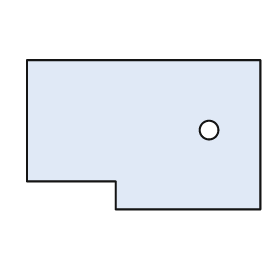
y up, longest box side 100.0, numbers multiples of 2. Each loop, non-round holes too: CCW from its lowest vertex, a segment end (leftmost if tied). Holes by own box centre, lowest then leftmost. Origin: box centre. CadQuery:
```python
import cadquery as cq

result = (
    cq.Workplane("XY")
    .moveTo(-12.0, -32.0)
    .lineTo(50.0, -32.0)
    .lineTo(50.0, 32.0)
    .lineTo(-50.0, 32.0)
    .lineTo(-50.0, -20.0)
    .lineTo(-12.0, -20.0)
    .close()
    .moveTo(28.0, 2.0)
    .circle(4.0)
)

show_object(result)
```